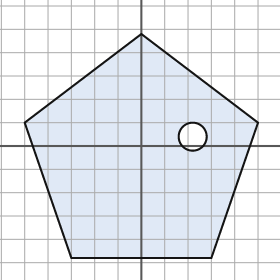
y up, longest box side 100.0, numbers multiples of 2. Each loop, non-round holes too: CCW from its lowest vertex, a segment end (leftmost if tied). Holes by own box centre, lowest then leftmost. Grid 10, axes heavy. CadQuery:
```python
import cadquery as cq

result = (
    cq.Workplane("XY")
    .moveTo(-30.0, -48.0)
    .lineTo(30.0, -48.0)
    .lineTo(50.0, 10.0)
    .lineTo(0.0, 48.0)
    .lineTo(-50.0, 10.0)
    .close()
    .moveTo(22.0, 4.0)
    .circle(6.0)
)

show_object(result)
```